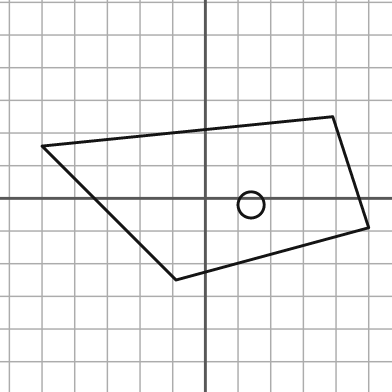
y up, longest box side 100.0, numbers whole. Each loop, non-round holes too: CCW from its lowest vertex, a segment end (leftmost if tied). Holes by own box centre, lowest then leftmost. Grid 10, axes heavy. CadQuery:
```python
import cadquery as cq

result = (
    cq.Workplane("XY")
    .moveTo(-9.0, -25.0)
    .lineTo(50.0, -9.0)
    .lineTo(39.0, 25.0)
    .lineTo(-50.0, 16.0)
    .close()
    .moveTo(14.0, -2.0)
    .circle(4.0)
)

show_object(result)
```